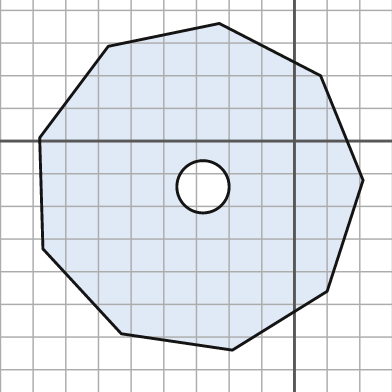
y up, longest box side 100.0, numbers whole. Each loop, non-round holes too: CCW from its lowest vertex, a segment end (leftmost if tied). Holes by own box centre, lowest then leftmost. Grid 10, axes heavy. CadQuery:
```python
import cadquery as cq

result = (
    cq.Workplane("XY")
    .moveTo(-19.0, -64.0)
    .lineTo(10.0, -46.0)
    .lineTo(21.0, -12.0)
    .lineTo(8.0, 20.0)
    .lineTo(-23.0, 36.0)
    .lineTo(-57.0, 29.0)
    .lineTo(-78.0, 1.0)
    .lineTo(-77.0, -33.0)
    .lineTo(-53.0, -59.0)
    .close()
    .moveTo(-28.0, -14.0)
    .circle(8.0)
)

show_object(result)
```